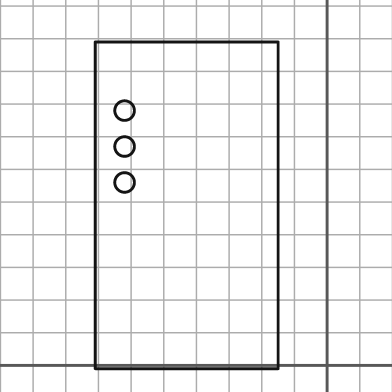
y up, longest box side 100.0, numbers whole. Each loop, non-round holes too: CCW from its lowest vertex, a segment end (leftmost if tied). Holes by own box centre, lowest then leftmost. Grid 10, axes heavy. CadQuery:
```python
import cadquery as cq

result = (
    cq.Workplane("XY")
    .moveTo(-71.0, -1.0)
    .lineTo(-15.0, -1.0)
    .lineTo(-15.0, 99.0)
    .lineTo(-71.0, 99.0)
    .close()
    .moveTo(-62.0, 56.0)
    .circle(3.0)
    .moveTo(-62.0, 67.0)
    .circle(3.0)
    .moveTo(-62.0, 78.0)
    .circle(3.0)
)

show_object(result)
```